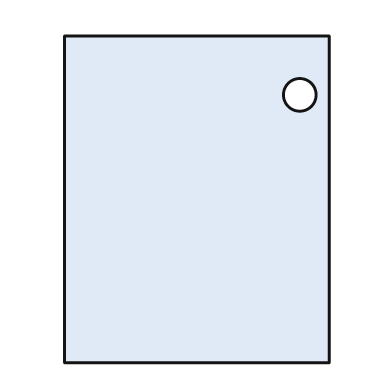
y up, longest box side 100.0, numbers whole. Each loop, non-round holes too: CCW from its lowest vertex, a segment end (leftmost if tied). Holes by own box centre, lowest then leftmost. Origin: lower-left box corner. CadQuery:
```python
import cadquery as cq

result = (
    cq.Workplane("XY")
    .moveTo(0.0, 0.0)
    .lineTo(81.0, 0.0)
    .lineTo(81.0, 100.0)
    .lineTo(0.0, 100.0)
    .close()
    .moveTo(72.0, 82.0)
    .circle(5.0)
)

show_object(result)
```